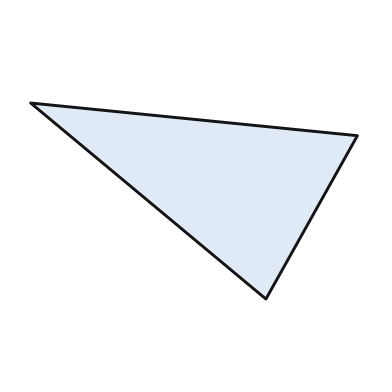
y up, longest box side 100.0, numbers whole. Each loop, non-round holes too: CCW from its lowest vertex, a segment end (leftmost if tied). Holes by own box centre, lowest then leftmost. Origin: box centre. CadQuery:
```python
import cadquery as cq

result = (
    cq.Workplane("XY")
    .moveTo(22.0, -30.0)
    .lineTo(50.0, 20.0)
    .lineTo(-50.0, 30.0)
    .close()
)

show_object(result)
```